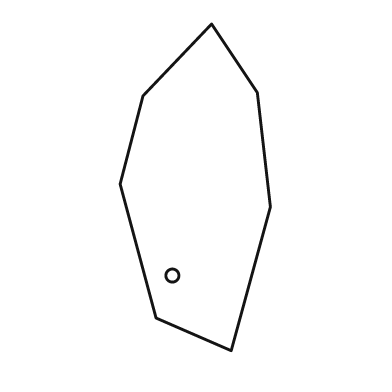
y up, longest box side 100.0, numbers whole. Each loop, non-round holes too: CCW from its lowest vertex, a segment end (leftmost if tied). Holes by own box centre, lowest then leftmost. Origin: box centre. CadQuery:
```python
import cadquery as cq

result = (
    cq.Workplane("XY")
    .moveTo(11.0, -50.0)
    .lineTo(23.0, -6.0)
    .lineTo(19.0, 29.0)
    .lineTo(5.0, 50.0)
    .lineTo(-16.0, 28.0)
    .lineTo(-23.0, 1.0)
    .lineTo(-12.0, -40.0)
    .close()
    .moveTo(-7.0, -27.0)
    .circle(2.0)
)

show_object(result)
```